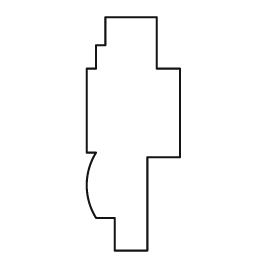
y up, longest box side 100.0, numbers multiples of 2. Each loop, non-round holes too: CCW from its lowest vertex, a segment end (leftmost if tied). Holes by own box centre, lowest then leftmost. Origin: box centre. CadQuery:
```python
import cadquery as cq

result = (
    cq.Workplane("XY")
    .moveTo(-8.0, -50.0)
    .lineTo(6.0, -50.0)
    .lineTo(6.0, -10.0)
    .lineTo(20.0, -10.0)
    .lineTo(20.0, 28.0)
    .lineTo(10.0, 28.0)
    .lineTo(10.0, 50.0)
    .lineTo(-12.0, 50.0)
    .lineTo(-12.0, 38.0)
    .lineTo(-16.0, 38.0)
    .lineTo(-16.0, 28.0)
    .lineTo(-20.0, 28.0)
    .lineTo(-20.0, -8.0)
    .lineTo(-16.0, -8.0)
    .threePointArc((-20.0, -22.0), (-16.0, -36.0))
    .lineTo(-8.0, -36.0)
    .close()
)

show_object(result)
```